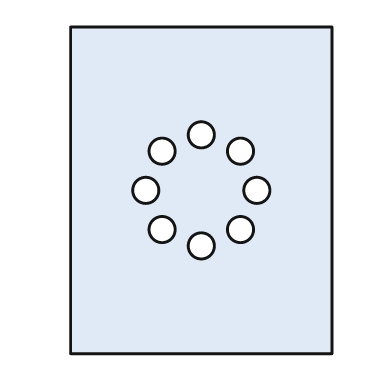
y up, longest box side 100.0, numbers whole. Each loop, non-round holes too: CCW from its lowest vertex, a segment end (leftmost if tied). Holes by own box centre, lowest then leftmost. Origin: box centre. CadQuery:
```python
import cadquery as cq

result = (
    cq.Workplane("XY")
    .moveTo(-40.0, -50.0)
    .lineTo(40.0, -50.0)
    .lineTo(40.0, 50.0)
    .lineTo(-40.0, 50.0)
    .close()
    .moveTo(0.0, -17.0)
    .circle(4.0)
    .moveTo(-12.0, -12.0)
    .circle(4.0)
    .moveTo(12.0, -12.0)
    .circle(4.0)
    .moveTo(-17.0, 0.0)
    .circle(4.0)
    .moveTo(17.0, 0.0)
    .circle(4.0)
    .moveTo(-12.0, 12.0)
    .circle(4.0)
    .moveTo(12.0, 12.0)
    .circle(4.0)
    .moveTo(0.0, 17.0)
    .circle(4.0)
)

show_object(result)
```